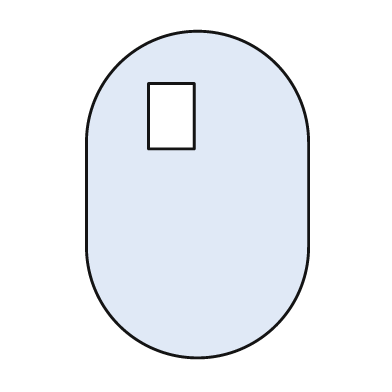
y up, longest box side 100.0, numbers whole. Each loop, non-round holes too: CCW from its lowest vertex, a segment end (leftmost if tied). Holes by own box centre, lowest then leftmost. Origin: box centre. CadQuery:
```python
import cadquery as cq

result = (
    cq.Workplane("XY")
    .moveTo(-34.0, -16.0)
    .threePointArc((0.0, -50.0), (34.0, -16.0))
    .lineTo(34.0, 16.0)
    .threePointArc((0.0, 50.0), (-34.0, 16.0))
    .close()
    .moveTo(-15.0, 14.0)
    .lineTo(-1.0, 14.0)
    .lineTo(-1.0, 34.0)
    .lineTo(-15.0, 34.0)
    .close()
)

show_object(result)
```